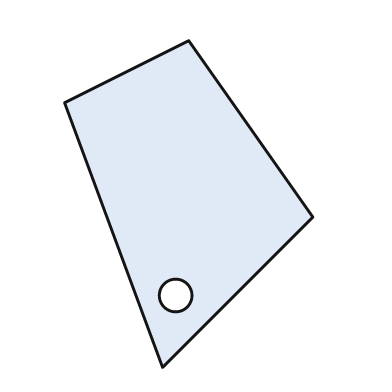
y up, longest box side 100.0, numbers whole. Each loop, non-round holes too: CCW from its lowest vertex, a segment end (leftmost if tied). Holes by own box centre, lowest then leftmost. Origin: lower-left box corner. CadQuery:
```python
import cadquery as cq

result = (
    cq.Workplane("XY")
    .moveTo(30.0, 0.0)
    .lineTo(76.0, 46.0)
    .lineTo(38.0, 100.0)
    .lineTo(0.0, 81.0)
    .close()
    .moveTo(34.0, 22.0)
    .circle(5.0)
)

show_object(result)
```